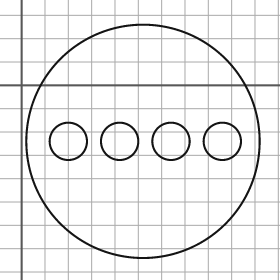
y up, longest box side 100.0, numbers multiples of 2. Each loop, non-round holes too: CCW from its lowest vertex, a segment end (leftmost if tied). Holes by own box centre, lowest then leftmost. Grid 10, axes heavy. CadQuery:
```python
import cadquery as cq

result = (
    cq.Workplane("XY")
    .moveTo(52.0, -24.0)
    .circle(50.0)
    .moveTo(20.0, -24.0)
    .circle(8.0)
    .moveTo(42.0, -24.0)
    .circle(8.0)
    .moveTo(64.0, -24.0)
    .circle(8.0)
    .moveTo(86.0, -24.0)
    .circle(8.0)
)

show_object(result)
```